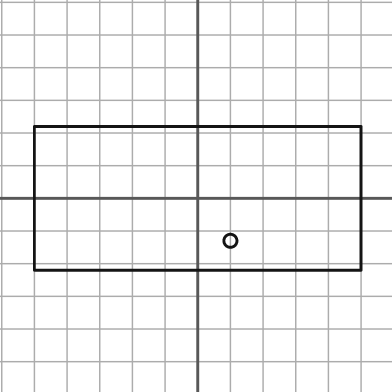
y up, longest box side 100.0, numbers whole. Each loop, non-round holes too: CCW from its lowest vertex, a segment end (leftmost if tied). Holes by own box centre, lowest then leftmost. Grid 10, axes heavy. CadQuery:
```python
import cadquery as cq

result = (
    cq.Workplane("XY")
    .moveTo(-50.0, -22.0)
    .lineTo(50.0, -22.0)
    .lineTo(50.0, 22.0)
    .lineTo(-50.0, 22.0)
    .close()
    .moveTo(10.0, -13.0)
    .circle(2.0)
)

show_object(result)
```